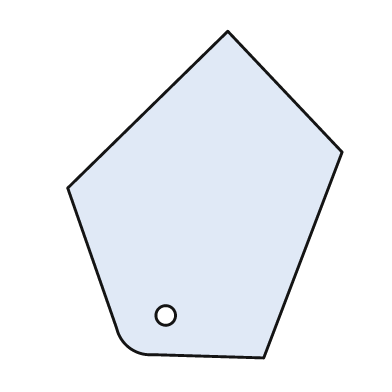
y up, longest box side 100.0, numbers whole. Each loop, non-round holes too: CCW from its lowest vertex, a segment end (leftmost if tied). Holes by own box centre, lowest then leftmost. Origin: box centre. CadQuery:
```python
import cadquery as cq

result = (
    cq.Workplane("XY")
    .moveTo(18.0, -50.0)
    .lineTo(42.0, 13.0)
    .lineTo(7.0, 50.0)
    .lineTo(-42.0, 2.0)
    .lineTo(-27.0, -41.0)
    .threePointArc((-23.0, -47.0), (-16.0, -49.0))
    .close()
    .moveTo(-12.0, -37.0)
    .circle(3.0)
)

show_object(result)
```